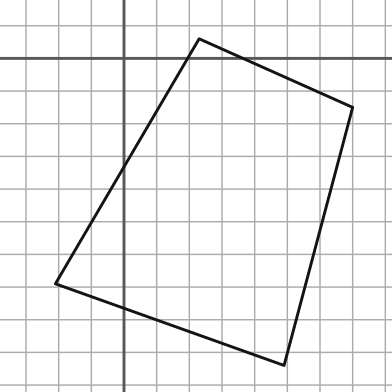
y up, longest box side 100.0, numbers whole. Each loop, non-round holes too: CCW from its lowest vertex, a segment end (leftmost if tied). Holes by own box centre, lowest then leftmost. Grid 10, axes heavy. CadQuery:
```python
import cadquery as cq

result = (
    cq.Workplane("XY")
    .moveTo(49.0, -94.0)
    .lineTo(70.0, -15.0)
    .lineTo(23.0, 6.0)
    .lineTo(-21.0, -69.0)
    .close()
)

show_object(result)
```